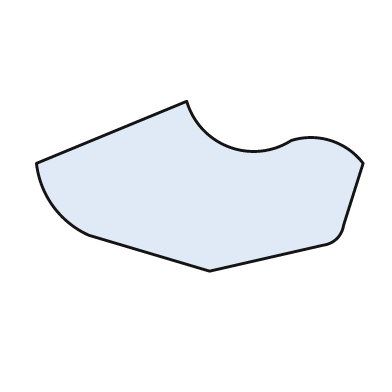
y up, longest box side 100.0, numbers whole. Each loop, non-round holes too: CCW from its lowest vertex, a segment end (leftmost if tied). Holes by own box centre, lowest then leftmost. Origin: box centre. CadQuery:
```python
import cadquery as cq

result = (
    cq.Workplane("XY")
    .moveTo(3.0, -26.0)
    .lineTo(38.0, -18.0)
    .threePointArc((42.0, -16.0), (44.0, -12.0))
    .lineTo(50.0, 7.0)
    .threePointArc((40.0, 14.0), (28.0, 14.0))
    .threePointArc((9.0, 12.0), (-4.0, 26.0))
    .lineTo(-50.0, 7.0)
    .threePointArc((-45.0, -6.0), (-34.0, -15.0))
    .close()
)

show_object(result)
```